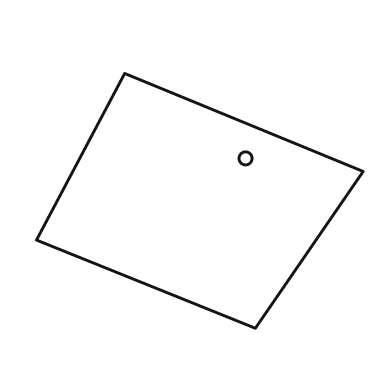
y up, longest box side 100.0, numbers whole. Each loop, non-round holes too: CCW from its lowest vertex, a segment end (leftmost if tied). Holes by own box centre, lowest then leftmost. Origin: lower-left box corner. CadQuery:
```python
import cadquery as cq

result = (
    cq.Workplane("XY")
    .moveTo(67.0, 0.0)
    .lineTo(100.0, 48.0)
    .lineTo(27.0, 78.0)
    .lineTo(0.0, 27.0)
    .close()
    .moveTo(64.0, 52.0)
    .circle(2.0)
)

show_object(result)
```